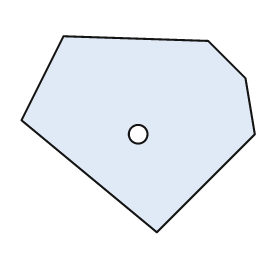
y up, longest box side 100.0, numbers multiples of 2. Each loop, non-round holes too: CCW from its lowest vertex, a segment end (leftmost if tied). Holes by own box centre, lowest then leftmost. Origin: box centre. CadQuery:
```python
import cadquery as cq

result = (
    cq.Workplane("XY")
    .moveTo(8.0, -42.0)
    .lineTo(50.0, 0.0)
    .lineTo(46.0, 24.0)
    .lineTo(30.0, 40.0)
    .lineTo(-32.0, 42.0)
    .lineTo(-50.0, 6.0)
    .close()
    .moveTo(0.0, 0.0)
    .circle(4.0)
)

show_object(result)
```